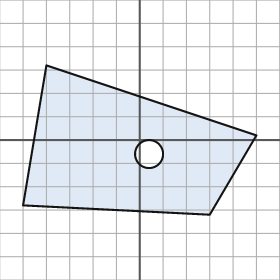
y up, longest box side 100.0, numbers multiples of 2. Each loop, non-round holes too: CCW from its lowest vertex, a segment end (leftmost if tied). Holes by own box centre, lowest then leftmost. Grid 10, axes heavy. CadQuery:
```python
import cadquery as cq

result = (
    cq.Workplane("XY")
    .moveTo(30.0, -32.0)
    .lineTo(50.0, 2.0)
    .lineTo(-40.0, 32.0)
    .lineTo(-50.0, -28.0)
    .close()
    .moveTo(4.0, -6.0)
    .circle(6.0)
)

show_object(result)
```